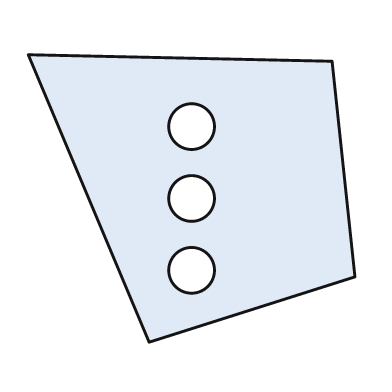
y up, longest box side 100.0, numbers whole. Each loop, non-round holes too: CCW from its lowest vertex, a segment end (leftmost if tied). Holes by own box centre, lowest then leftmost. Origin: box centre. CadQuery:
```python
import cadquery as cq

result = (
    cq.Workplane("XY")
    .moveTo(-13.0, -44.0)
    .lineTo(50.0, -24.0)
    .lineTo(43.0, 42.0)
    .lineTo(-50.0, 44.0)
    .close()
    .moveTo(0.0, -22.0)
    .circle(7.0)
    .moveTo(0.0, 0.0)
    .circle(7.0)
    .moveTo(0.0, 22.0)
    .circle(7.0)
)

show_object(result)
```